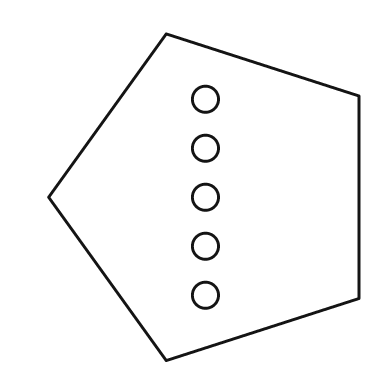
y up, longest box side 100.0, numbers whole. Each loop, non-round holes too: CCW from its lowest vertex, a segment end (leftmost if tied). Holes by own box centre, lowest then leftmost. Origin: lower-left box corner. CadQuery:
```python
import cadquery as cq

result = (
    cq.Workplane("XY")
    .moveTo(36.0, 0.0)
    .lineTo(95.0, 19.0)
    .lineTo(95.0, 81.0)
    .lineTo(36.0, 100.0)
    .lineTo(0.0, 50.0)
    .close()
    .moveTo(48.0, 20.0)
    .circle(4.0)
    .moveTo(48.0, 35.0)
    .circle(4.0)
    .moveTo(48.0, 50.0)
    .circle(4.0)
    .moveTo(48.0, 65.0)
    .circle(4.0)
    .moveTo(48.0, 80.0)
    .circle(4.0)
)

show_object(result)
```